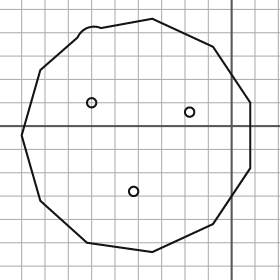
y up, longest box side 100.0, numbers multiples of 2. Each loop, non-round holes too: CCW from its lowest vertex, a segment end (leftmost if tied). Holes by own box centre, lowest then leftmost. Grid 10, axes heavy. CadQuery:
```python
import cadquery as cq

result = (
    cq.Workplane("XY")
    .moveTo(-34.0, -54.0)
    .lineTo(-8.0, -42.0)
    .lineTo(8.0, -18.0)
    .lineTo(8.0, 10.0)
    .lineTo(-8.0, 34.0)
    .lineTo(-34.0, 46.0)
    .lineTo(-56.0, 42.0)
    .threePointArc((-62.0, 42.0), (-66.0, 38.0))
    .lineTo(-82.0, 24.0)
    .lineTo(-90.0, -4.0)
    .lineTo(-82.0, -32.0)
    .lineTo(-62.0, -50.0)
    .close()
    .moveTo(-42.0, -28.0)
    .circle(2.0)
    .moveTo(-18.0, 6.0)
    .circle(2.0)
    .moveTo(-60.0, 10.0)
    .circle(2.0)
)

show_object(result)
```